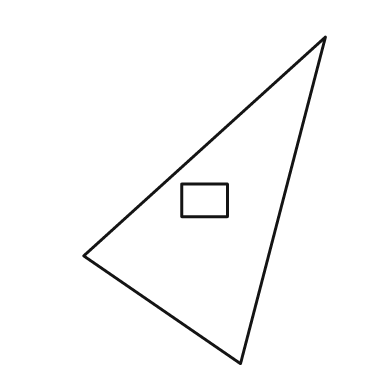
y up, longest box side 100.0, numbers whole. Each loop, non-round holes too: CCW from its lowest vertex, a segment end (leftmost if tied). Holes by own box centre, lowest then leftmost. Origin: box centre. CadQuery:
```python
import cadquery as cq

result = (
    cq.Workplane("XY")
    .moveTo(11.0, -50.0)
    .lineTo(37.0, 50.0)
    .lineTo(-37.0, -17.0)
    .close()
    .moveTo(-7.0, -5.0)
    .lineTo(7.0, -5.0)
    .lineTo(7.0, 5.0)
    .lineTo(-7.0, 5.0)
    .close()
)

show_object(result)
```